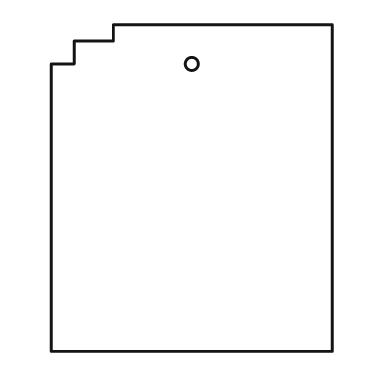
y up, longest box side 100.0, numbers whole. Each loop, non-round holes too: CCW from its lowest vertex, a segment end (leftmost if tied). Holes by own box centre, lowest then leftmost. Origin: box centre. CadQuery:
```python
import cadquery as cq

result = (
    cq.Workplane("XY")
    .moveTo(-43.0, -50.0)
    .lineTo(43.0, -50.0)
    .lineTo(43.0, 50.0)
    .lineTo(-24.0, 50.0)
    .lineTo(-24.0, 45.0)
    .lineTo(-36.0, 45.0)
    .lineTo(-36.0, 38.0)
    .lineTo(-43.0, 38.0)
    .close()
    .moveTo(0.0, 38.0)
    .circle(2.0)
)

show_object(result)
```